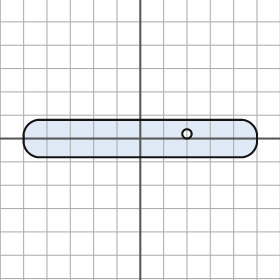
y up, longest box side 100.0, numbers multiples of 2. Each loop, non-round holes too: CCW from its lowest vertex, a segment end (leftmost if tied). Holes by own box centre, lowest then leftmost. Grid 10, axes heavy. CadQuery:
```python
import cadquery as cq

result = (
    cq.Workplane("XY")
    .moveTo(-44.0, -8.0)
    .lineTo(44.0, -8.0)
    .threePointArc((48.0, -6.0), (50.0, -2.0))
    .lineTo(50.0, 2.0)
    .threePointArc((48.0, 6.0), (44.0, 8.0))
    .lineTo(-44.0, 8.0)
    .threePointArc((-48.0, 6.0), (-50.0, 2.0))
    .lineTo(-50.0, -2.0)
    .threePointArc((-48.0, -6.0), (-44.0, -8.0))
    .close()
    .moveTo(20.0, 2.0)
    .circle(2.0)
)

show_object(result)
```